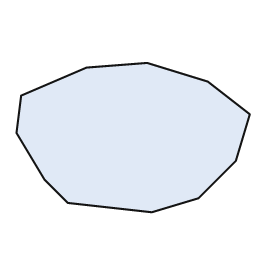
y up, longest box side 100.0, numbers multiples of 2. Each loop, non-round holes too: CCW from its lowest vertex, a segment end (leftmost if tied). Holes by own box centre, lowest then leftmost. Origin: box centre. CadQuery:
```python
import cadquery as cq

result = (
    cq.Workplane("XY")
    .moveTo(8.0, -32.0)
    .lineTo(28.0, -26.0)
    .lineTo(44.0, -10.0)
    .lineTo(50.0, 10.0)
    .lineTo(32.0, 24.0)
    .lineTo(6.0, 32.0)
    .lineTo(-20.0, 30.0)
    .lineTo(-48.0, 18.0)
    .lineTo(-50.0, 2.0)
    .lineTo(-38.0, -18.0)
    .lineTo(-28.0, -28.0)
    .close()
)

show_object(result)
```